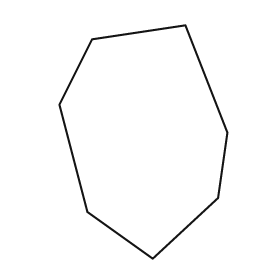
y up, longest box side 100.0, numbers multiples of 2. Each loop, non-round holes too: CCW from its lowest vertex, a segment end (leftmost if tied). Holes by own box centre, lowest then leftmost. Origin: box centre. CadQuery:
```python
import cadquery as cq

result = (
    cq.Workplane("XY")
    .moveTo(4.0, -50.0)
    .lineTo(32.0, -24.0)
    .lineTo(36.0, 4.0)
    .lineTo(18.0, 50.0)
    .lineTo(-22.0, 44.0)
    .lineTo(-36.0, 16.0)
    .lineTo(-24.0, -30.0)
    .close()
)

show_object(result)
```